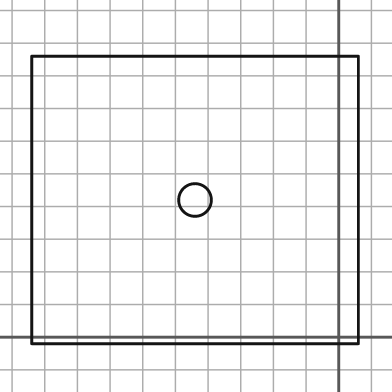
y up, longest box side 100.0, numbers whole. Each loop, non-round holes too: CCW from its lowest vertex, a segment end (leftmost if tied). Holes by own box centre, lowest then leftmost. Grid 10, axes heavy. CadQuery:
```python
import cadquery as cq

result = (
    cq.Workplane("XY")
    .moveTo(-94.0, -2.0)
    .lineTo(6.0, -2.0)
    .lineTo(6.0, 86.0)
    .lineTo(-94.0, 86.0)
    .close()
    .moveTo(-44.0, 42.0)
    .circle(5.0)
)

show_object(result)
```